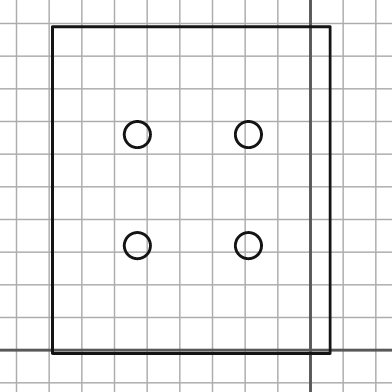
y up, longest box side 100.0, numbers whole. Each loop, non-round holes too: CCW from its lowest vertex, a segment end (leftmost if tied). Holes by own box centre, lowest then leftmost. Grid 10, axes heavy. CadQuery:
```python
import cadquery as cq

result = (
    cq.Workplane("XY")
    .moveTo(-79.0, -1.0)
    .lineTo(6.0, -1.0)
    .lineTo(6.0, 99.0)
    .lineTo(-79.0, 99.0)
    .close()
    .moveTo(-53.0, 32.0)
    .circle(4.0)
    .moveTo(-19.0, 32.0)
    .circle(4.0)
    .moveTo(-53.0, 66.0)
    .circle(4.0)
    .moveTo(-19.0, 66.0)
    .circle(4.0)
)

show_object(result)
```